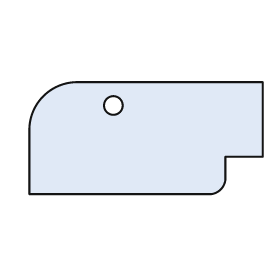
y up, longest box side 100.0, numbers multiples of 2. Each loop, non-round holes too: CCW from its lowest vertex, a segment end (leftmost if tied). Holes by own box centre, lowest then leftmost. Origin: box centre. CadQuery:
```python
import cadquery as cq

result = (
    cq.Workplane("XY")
    .moveTo(-50.0, -24.0)
    .lineTo(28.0, -24.0)
    .threePointArc((32.0, -22.0), (34.0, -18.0))
    .lineTo(34.0, -8.0)
    .lineTo(50.0, -8.0)
    .lineTo(50.0, 24.0)
    .lineTo(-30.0, 24.0)
    .threePointArc((-44.0, 18.0), (-50.0, 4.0))
    .close()
    .moveTo(-14.0, 14.0)
    .circle(4.0)
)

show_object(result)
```